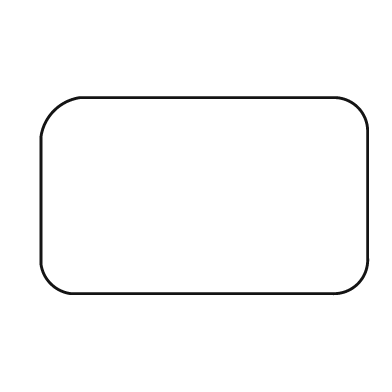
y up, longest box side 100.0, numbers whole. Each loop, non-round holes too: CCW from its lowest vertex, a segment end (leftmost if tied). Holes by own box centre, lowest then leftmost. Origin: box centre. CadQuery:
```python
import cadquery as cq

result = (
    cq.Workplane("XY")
    .moveTo(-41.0, -30.0)
    .lineTo(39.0, -30.0)
    .threePointArc((47.0, -27.0), (50.0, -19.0))
    .lineTo(50.0, 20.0)
    .threePointArc((47.0, 27.0), (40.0, 30.0))
    .lineTo(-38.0, 30.0)
    .threePointArc((-46.0, 26.0), (-50.0, 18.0))
    .lineTo(-50.0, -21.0)
    .threePointArc((-47.0, -27.0), (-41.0, -30.0))
    .close()
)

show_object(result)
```